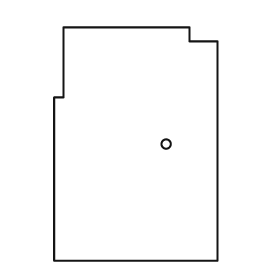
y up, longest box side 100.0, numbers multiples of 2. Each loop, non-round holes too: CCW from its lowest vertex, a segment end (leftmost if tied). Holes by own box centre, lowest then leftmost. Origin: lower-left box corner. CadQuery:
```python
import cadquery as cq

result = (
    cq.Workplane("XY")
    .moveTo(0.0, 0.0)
    .lineTo(70.0, 0.0)
    .lineTo(70.0, 94.0)
    .lineTo(58.0, 94.0)
    .lineTo(58.0, 100.0)
    .lineTo(4.0, 100.0)
    .lineTo(4.0, 70.0)
    .lineTo(0.0, 70.0)
    .close()
    .moveTo(48.0, 50.0)
    .circle(2.0)
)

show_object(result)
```